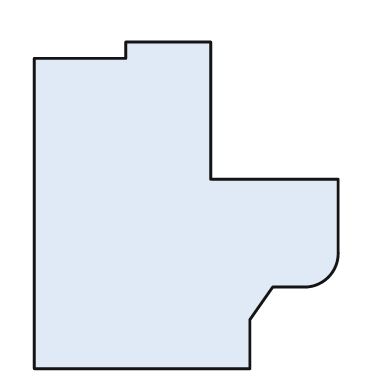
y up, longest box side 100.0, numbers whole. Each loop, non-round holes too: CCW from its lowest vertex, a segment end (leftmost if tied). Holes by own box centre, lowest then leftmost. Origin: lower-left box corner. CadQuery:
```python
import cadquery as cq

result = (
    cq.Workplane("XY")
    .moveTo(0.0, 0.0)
    .lineTo(66.0, 0.0)
    .lineTo(66.0, 15.0)
    .lineTo(73.0, 25.0)
    .lineTo(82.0, 25.0)
    .threePointArc((90.0, 28.0), (93.0, 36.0))
    .lineTo(93.0, 58.0)
    .lineTo(54.0, 58.0)
    .lineTo(54.0, 100.0)
    .lineTo(28.0, 100.0)
    .lineTo(28.0, 95.0)
    .lineTo(0.0, 95.0)
    .close()
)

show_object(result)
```